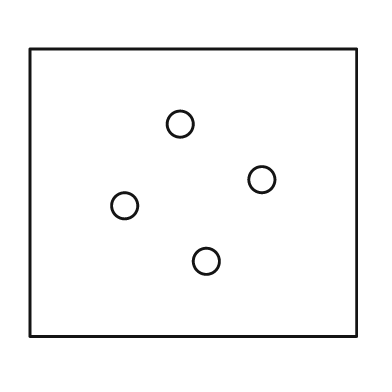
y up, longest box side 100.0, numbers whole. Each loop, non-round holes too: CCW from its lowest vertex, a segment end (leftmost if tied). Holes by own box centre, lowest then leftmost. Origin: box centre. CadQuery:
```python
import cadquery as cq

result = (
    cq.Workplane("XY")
    .moveTo(-50.0, -44.0)
    .lineTo(50.0, -44.0)
    .lineTo(50.0, 44.0)
    .lineTo(-50.0, 44.0)
    .close()
    .moveTo(4.0, -21.0)
    .circle(4.0)
    .moveTo(-21.0, -4.0)
    .circle(4.0)
    .moveTo(21.0, 4.0)
    .circle(4.0)
    .moveTo(-4.0, 21.0)
    .circle(4.0)
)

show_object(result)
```